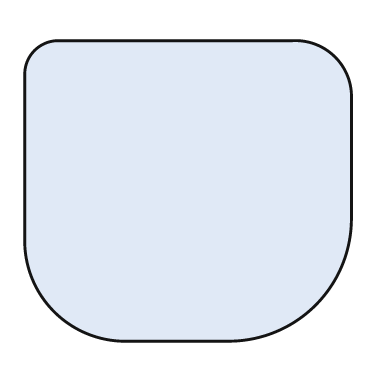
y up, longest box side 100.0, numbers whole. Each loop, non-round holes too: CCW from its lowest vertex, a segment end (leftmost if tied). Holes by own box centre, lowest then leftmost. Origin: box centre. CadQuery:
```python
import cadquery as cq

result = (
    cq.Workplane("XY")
    .moveTo(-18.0, -46.0)
    .lineTo(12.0, -46.0)
    .threePointArc((39.0, -35.0), (50.0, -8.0))
    .lineTo(50.0, 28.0)
    .threePointArc((45.0, 41.0), (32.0, 46.0))
    .lineTo(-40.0, 46.0)
    .threePointArc((-47.0, 43.0), (-50.0, 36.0))
    .lineTo(-50.0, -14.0)
    .threePointArc((-41.0, -37.0), (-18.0, -46.0))
    .close()
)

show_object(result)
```